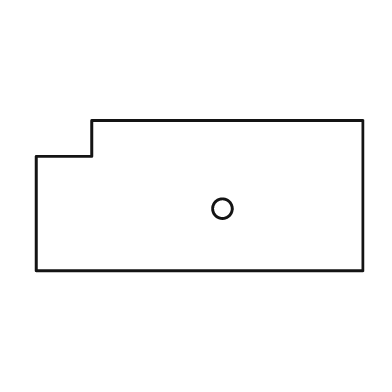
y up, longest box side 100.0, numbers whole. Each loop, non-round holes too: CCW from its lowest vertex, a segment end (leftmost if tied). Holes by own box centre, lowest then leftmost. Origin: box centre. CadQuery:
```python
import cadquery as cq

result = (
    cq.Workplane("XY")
    .moveTo(-50.0, -23.0)
    .lineTo(50.0, -23.0)
    .lineTo(50.0, 23.0)
    .lineTo(-33.0, 23.0)
    .lineTo(-33.0, 12.0)
    .lineTo(-50.0, 12.0)
    .close()
    .moveTo(7.0, -4.0)
    .circle(3.0)
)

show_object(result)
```